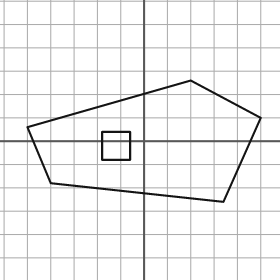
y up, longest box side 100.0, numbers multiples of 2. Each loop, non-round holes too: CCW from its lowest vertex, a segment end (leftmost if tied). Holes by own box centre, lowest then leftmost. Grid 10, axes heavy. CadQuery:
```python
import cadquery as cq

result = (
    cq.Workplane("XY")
    .moveTo(34.0, -26.0)
    .lineTo(50.0, 10.0)
    .lineTo(20.0, 26.0)
    .lineTo(-50.0, 6.0)
    .lineTo(-40.0, -18.0)
    .close()
    .moveTo(-18.0, -8.0)
    .lineTo(-6.0, -8.0)
    .lineTo(-6.0, 4.0)
    .lineTo(-18.0, 4.0)
    .close()
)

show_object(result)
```